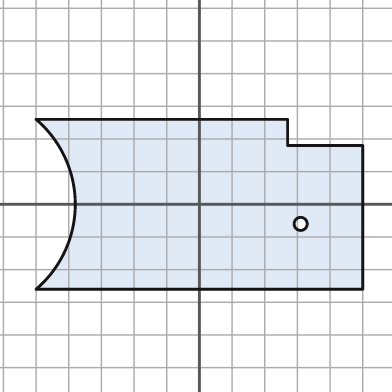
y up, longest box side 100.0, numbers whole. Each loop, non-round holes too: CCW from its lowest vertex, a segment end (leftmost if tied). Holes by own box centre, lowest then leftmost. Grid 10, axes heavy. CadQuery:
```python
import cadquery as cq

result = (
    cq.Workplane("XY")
    .moveTo(-50.0, -26.0)
    .lineTo(50.0, -26.0)
    .lineTo(50.0, 18.0)
    .lineTo(27.0, 18.0)
    .lineTo(27.0, 26.0)
    .lineTo(-50.0, 26.0)
    .threePointArc((-38.0, 0.0), (-50.0, -26.0))
    .close()
    .moveTo(31.0, -6.0)
    .circle(2.0)
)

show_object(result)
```